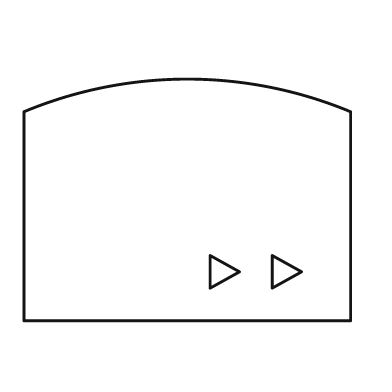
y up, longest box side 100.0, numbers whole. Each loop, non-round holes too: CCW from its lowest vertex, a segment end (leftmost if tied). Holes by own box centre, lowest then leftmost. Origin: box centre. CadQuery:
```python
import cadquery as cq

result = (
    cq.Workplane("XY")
    .moveTo(-50.0, -37.0)
    .lineTo(50.0, -37.0)
    .lineTo(50.0, 27.0)
    .threePointArc((0.0, 37.0), (-50.0, 27.0))
    .close()
    .moveTo(7.0, -27.0)
    .lineTo(16.0, -22.0)
    .lineTo(7.0, -17.0)
    .close()
    .moveTo(26.0, -27.0)
    .lineTo(35.0, -22.0)
    .lineTo(26.0, -17.0)
    .close()
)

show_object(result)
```